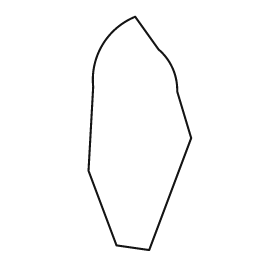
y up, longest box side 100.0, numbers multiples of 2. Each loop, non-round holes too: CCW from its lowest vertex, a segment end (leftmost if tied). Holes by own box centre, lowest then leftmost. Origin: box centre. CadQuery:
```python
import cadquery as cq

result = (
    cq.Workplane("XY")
    .moveTo(4.0, -50.0)
    .lineTo(22.0, -2.0)
    .lineTo(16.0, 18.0)
    .threePointArc((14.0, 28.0), (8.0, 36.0))
    .lineTo(-2.0, 50.0)
    .threePointArc((-16.0, 38.0), (-20.0, 20.0))
    .lineTo(-22.0, -16.0)
    .lineTo(-10.0, -48.0)
    .close()
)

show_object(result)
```